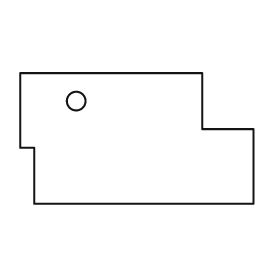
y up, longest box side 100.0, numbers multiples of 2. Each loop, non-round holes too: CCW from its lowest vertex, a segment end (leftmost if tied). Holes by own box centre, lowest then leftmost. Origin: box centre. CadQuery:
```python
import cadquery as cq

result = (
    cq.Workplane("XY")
    .moveTo(-44.0, -28.0)
    .lineTo(50.0, -28.0)
    .lineTo(50.0, 4.0)
    .lineTo(28.0, 4.0)
    .lineTo(28.0, 28.0)
    .lineTo(-50.0, 28.0)
    .lineTo(-50.0, -4.0)
    .lineTo(-44.0, -4.0)
    .close()
    .moveTo(-26.0, 16.0)
    .circle(4.0)
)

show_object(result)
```